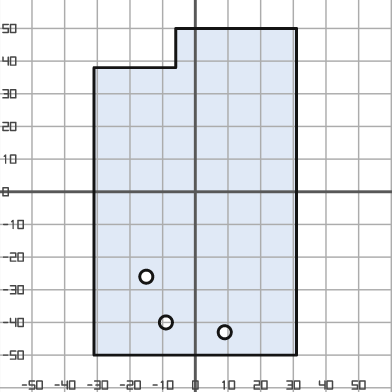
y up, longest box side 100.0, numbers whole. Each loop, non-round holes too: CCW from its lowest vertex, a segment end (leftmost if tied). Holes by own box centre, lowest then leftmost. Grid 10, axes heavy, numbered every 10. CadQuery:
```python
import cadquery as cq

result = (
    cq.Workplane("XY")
    .moveTo(-31.0, -50.0)
    .lineTo(31.0, -50.0)
    .lineTo(31.0, 50.0)
    .lineTo(-6.0, 50.0)
    .lineTo(-6.0, 38.0)
    .lineTo(-31.0, 38.0)
    .close()
    .moveTo(9.0, -43.0)
    .circle(2.0)
    .moveTo(-9.0, -40.0)
    .circle(2.0)
    .moveTo(-15.0, -26.0)
    .circle(2.0)
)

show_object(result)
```